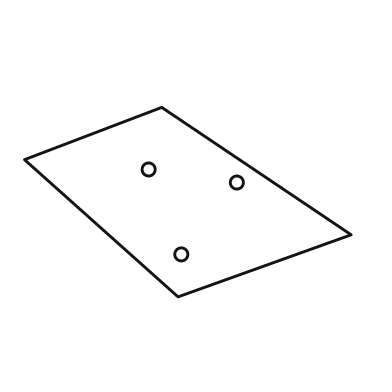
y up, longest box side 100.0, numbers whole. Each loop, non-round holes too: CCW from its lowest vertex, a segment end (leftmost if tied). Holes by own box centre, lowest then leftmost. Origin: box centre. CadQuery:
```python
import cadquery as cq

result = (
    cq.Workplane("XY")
    .moveTo(-3.0, -29.0)
    .lineTo(50.0, -10.0)
    .lineTo(-8.0, 29.0)
    .lineTo(-50.0, 13.0)
    .close()
    .moveTo(-2.0, -16.0)
    .circle(2.0)
    .moveTo(15.0, 6.0)
    .circle(2.0)
    .moveTo(-12.0, 10.0)
    .circle(2.0)
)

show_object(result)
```